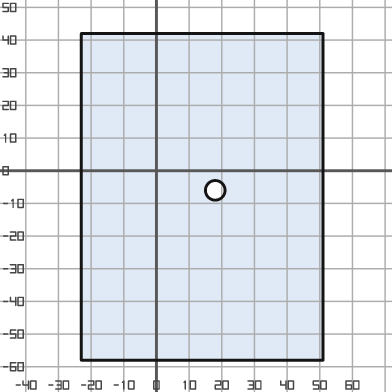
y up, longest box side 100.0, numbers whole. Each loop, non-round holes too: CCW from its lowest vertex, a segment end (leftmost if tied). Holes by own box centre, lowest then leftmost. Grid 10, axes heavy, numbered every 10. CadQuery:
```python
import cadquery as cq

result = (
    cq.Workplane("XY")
    .moveTo(-23.0, -58.0)
    .lineTo(51.0, -58.0)
    .lineTo(51.0, 42.0)
    .lineTo(-23.0, 42.0)
    .close()
    .moveTo(18.0, -6.0)
    .circle(3.0)
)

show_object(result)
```